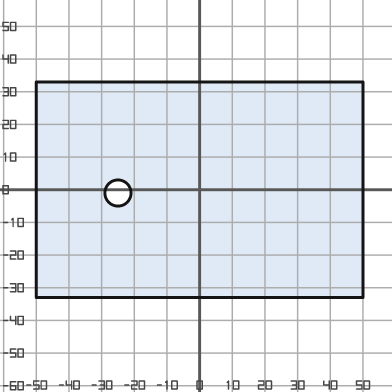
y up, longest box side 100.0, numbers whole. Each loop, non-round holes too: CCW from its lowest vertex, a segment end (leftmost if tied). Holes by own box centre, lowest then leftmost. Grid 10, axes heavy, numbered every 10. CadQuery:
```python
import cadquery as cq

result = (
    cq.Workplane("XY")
    .moveTo(-50.0, -33.0)
    .lineTo(50.0, -33.0)
    .lineTo(50.0, 33.0)
    .lineTo(-50.0, 33.0)
    .close()
    .moveTo(-25.0, -1.0)
    .circle(4.0)
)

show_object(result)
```